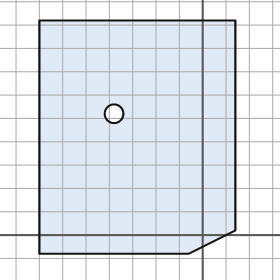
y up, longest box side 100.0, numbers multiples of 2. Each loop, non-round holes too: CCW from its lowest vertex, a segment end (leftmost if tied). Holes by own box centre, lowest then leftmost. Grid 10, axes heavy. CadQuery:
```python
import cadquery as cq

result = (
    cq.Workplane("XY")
    .moveTo(-70.0, -8.0)
    .lineTo(-6.0, -8.0)
    .lineTo(14.0, 2.0)
    .lineTo(14.0, 92.0)
    .lineTo(-70.0, 92.0)
    .close()
    .moveTo(-38.0, 52.0)
    .circle(4.0)
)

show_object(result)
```